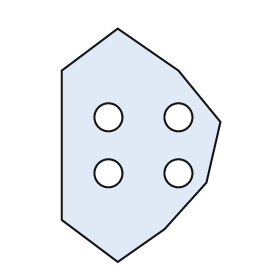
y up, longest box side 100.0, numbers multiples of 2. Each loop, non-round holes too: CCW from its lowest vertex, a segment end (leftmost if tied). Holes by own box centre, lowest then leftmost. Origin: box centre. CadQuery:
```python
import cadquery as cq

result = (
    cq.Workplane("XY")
    .moveTo(-10.0, -50.0)
    .lineTo(10.0, -36.0)
    .lineTo(28.0, -16.0)
    .lineTo(34.0, 10.0)
    .lineTo(16.0, 32.0)
    .lineTo(-10.0, 50.0)
    .lineTo(-34.0, 32.0)
    .lineTo(-34.0, -32.0)
    .close()
    .moveTo(-14.0, -12.0)
    .circle(6.0)
    .moveTo(16.0, -12.0)
    .circle(6.0)
    .moveTo(-14.0, 12.0)
    .circle(6.0)
    .moveTo(16.0, 12.0)
    .circle(6.0)
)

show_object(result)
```